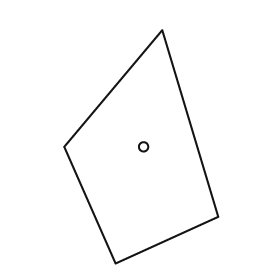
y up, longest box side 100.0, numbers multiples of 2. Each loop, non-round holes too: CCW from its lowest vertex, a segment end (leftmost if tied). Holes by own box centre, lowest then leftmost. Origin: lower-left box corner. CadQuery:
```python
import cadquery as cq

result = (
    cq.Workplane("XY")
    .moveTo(22.0, 0.0)
    .lineTo(66.0, 20.0)
    .lineTo(42.0, 100.0)
    .lineTo(0.0, 50.0)
    .close()
    .moveTo(34.0, 50.0)
    .circle(2.0)
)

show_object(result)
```